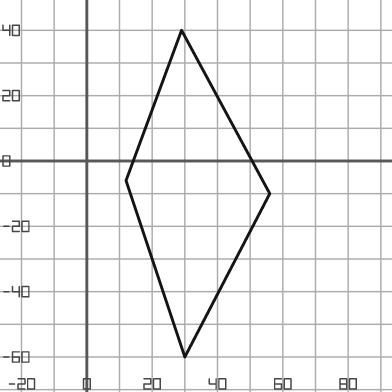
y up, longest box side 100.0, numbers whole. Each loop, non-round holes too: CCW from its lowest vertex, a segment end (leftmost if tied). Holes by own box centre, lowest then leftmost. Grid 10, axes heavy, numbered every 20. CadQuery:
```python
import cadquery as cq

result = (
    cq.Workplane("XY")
    .moveTo(30.0, -60.0)
    .lineTo(56.0, -10.0)
    .lineTo(29.0, 40.0)
    .lineTo(12.0, -6.0)
    .close()
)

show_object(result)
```